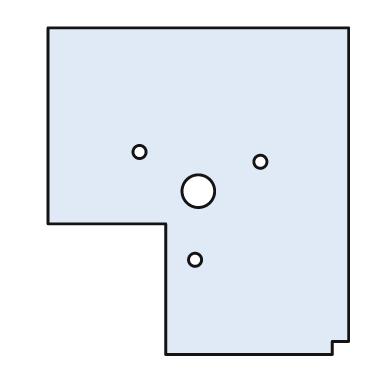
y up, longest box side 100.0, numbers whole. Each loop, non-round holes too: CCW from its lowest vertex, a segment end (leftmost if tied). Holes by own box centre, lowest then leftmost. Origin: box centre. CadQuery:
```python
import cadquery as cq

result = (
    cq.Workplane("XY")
    .moveTo(-10.0, -50.0)
    .lineTo(41.0, -50.0)
    .lineTo(41.0, -46.0)
    .lineTo(46.0, -46.0)
    .lineTo(46.0, 50.0)
    .lineTo(-46.0, 50.0)
    .lineTo(-46.0, -10.0)
    .lineTo(-10.0, -10.0)
    .close()
    .moveTo(-1.0, -21.0)
    .circle(2.0)
    .moveTo(0.0, 0.0)
    .circle(5.0)
    .moveTo(19.0, 9.0)
    .circle(2.0)
    .moveTo(-18.0, 12.0)
    .circle(2.0)
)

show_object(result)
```